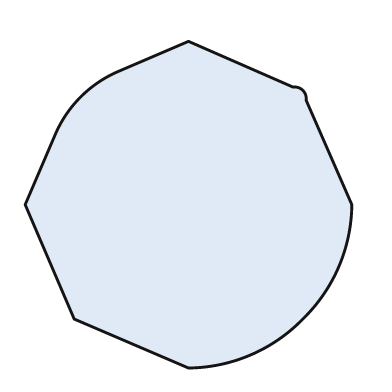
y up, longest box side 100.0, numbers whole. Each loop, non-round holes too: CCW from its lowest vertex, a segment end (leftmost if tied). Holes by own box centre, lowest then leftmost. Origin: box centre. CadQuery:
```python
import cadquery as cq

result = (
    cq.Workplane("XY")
    .moveTo(0.0, -50.0)
    .threePointArc((19.0, -46.0), (35.0, -35.0))
    .threePointArc((46.0, -19.0), (50.0, 0.0))
    .lineTo(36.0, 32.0)
    .threePointArc((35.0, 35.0), (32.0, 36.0))
    .lineTo(0.0, 50.0)
    .lineTo(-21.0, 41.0)
    .threePointArc((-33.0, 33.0), (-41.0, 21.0))
    .lineTo(-50.0, 0.0)
    .lineTo(-35.0, -35.0)
    .close()
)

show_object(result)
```